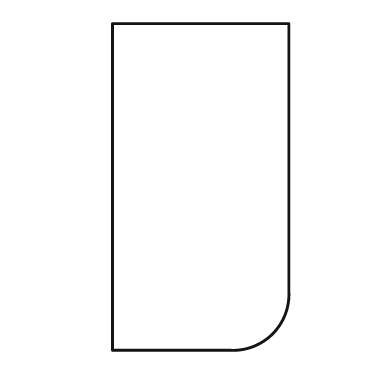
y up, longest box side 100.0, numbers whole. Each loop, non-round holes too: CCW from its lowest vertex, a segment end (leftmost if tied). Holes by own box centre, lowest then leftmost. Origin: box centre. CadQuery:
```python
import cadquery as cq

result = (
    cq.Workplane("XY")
    .moveTo(-27.0, -50.0)
    .lineTo(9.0, -50.0)
    .threePointArc((22.0, -45.0), (27.0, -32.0))
    .lineTo(27.0, 50.0)
    .lineTo(-27.0, 50.0)
    .close()
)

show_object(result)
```